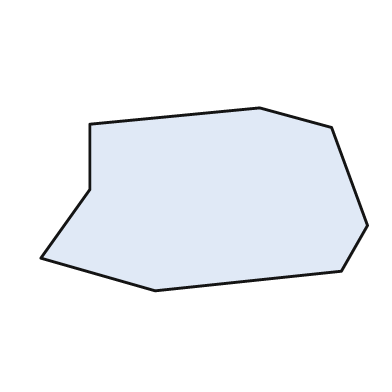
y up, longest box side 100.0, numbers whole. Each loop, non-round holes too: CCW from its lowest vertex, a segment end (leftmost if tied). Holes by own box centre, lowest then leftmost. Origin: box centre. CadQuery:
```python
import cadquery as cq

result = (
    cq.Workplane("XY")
    .moveTo(-15.0, -28.0)
    .lineTo(42.0, -22.0)
    .lineTo(50.0, -8.0)
    .lineTo(39.0, 22.0)
    .lineTo(17.0, 28.0)
    .lineTo(-35.0, 23.0)
    .lineTo(-35.0, 3.0)
    .lineTo(-50.0, -18.0)
    .close()
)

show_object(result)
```